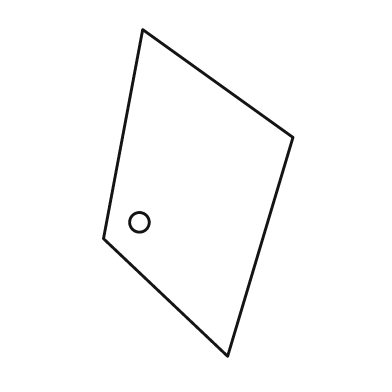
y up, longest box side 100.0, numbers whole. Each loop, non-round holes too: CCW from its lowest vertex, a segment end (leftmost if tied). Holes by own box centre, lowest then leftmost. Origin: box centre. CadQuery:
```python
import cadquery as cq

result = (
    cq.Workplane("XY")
    .moveTo(9.0, -50.0)
    .lineTo(29.0, 17.0)
    .lineTo(-17.0, 50.0)
    .lineTo(-29.0, -14.0)
    .close()
    .moveTo(-18.0, -9.0)
    .circle(3.0)
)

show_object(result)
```